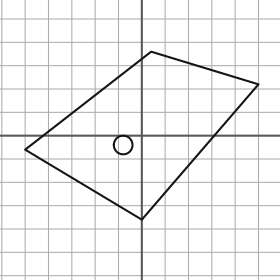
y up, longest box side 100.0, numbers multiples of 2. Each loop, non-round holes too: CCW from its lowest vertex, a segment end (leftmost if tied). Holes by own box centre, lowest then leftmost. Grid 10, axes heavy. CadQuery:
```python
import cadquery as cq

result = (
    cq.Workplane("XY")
    .moveTo(0.0, -36.0)
    .lineTo(50.0, 22.0)
    .lineTo(4.0, 36.0)
    .lineTo(-50.0, -6.0)
    .close()
    .moveTo(-8.0, -4.0)
    .circle(4.0)
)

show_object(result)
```